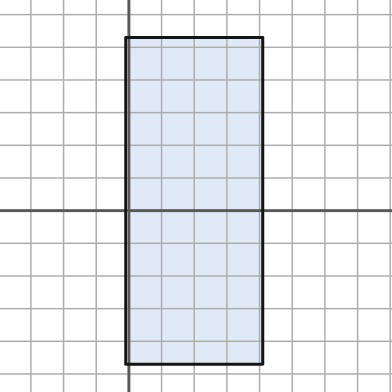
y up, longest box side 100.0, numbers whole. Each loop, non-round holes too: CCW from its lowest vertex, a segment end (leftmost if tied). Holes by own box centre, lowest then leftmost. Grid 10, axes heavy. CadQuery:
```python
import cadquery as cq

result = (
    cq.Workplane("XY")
    .moveTo(-1.0, -47.0)
    .lineTo(41.0, -47.0)
    .lineTo(41.0, 53.0)
    .lineTo(-1.0, 53.0)
    .close()
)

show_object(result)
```